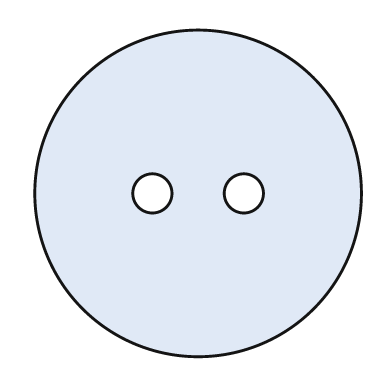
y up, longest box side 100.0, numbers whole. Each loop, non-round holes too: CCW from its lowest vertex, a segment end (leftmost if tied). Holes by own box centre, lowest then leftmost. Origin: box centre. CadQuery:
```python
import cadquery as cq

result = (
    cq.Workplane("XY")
    .moveTo(0.0, 0.0)
    .circle(50.0)
    .moveTo(-14.0, 0.0)
    .circle(6.0)
    .moveTo(14.0, 0.0)
    .circle(6.0)
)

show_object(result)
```